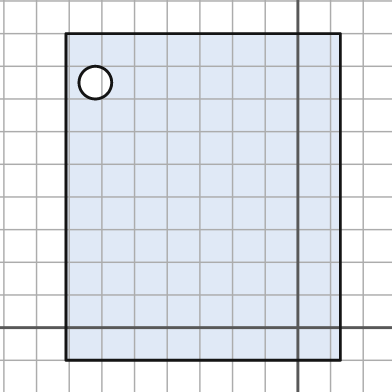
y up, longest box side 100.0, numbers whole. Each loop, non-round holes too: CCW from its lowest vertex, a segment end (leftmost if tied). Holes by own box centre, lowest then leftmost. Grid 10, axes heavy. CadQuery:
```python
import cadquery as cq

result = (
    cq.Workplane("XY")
    .moveTo(-71.0, -10.0)
    .lineTo(13.0, -10.0)
    .lineTo(13.0, 90.0)
    .lineTo(-71.0, 90.0)
    .close()
    .moveTo(-62.0, 75.0)
    .circle(5.0)
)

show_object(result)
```